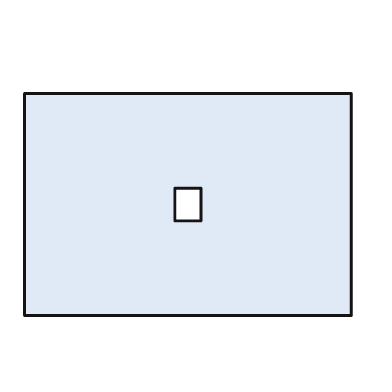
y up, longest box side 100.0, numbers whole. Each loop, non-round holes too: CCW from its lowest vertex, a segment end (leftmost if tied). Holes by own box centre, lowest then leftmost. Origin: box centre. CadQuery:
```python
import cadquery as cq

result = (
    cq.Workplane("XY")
    .moveTo(-50.0, -34.0)
    .lineTo(50.0, -34.0)
    .lineTo(50.0, 34.0)
    .lineTo(-50.0, 34.0)
    .close()
    .moveTo(-4.0, -5.0)
    .lineTo(4.0, -5.0)
    .lineTo(4.0, 5.0)
    .lineTo(-4.0, 5.0)
    .close()
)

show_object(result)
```